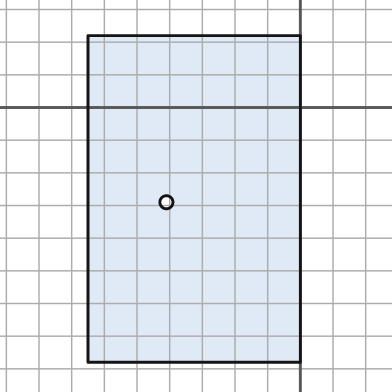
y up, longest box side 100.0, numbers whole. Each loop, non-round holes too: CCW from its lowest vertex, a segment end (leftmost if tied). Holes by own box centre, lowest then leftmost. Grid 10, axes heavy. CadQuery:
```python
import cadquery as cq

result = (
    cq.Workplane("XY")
    .moveTo(-65.0, -78.0)
    .lineTo(0.0, -78.0)
    .lineTo(0.0, 22.0)
    .lineTo(-65.0, 22.0)
    .close()
    .moveTo(-41.0, -29.0)
    .circle(2.0)
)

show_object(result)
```